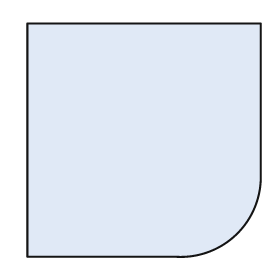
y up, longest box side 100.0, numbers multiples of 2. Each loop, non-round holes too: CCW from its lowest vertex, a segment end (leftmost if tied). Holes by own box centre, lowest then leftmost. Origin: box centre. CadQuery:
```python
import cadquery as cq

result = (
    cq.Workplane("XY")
    .moveTo(-50.0, -50.0)
    .lineTo(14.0, -50.0)
    .threePointArc((40.0, -40.0), (50.0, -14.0))
    .lineTo(50.0, 50.0)
    .lineTo(-50.0, 50.0)
    .close()
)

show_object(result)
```